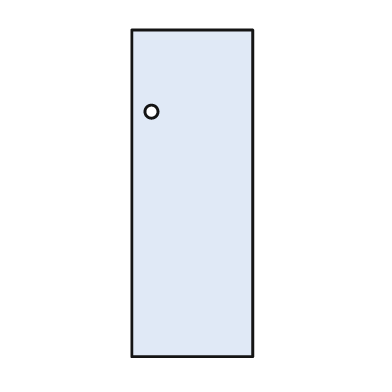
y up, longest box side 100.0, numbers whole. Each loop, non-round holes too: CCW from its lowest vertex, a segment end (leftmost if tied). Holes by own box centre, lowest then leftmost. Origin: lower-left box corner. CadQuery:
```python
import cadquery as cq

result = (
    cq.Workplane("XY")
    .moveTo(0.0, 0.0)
    .lineTo(37.0, 0.0)
    .lineTo(37.0, 100.0)
    .lineTo(0.0, 100.0)
    .close()
    .moveTo(6.0, 75.0)
    .circle(2.0)
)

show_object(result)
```